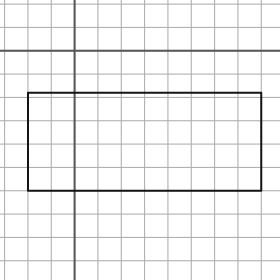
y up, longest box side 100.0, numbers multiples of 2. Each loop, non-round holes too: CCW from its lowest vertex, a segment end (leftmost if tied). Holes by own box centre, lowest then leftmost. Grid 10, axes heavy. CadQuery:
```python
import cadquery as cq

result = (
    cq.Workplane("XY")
    .moveTo(-20.0, -60.0)
    .lineTo(80.0, -60.0)
    .lineTo(80.0, -18.0)
    .lineTo(-20.0, -18.0)
    .close()
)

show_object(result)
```